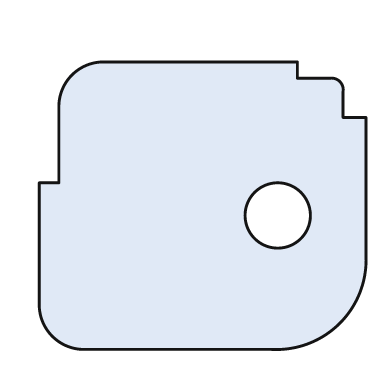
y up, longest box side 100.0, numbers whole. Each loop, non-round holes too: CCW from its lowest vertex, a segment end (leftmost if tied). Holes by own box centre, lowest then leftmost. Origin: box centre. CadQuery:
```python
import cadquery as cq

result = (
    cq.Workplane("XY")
    .moveTo(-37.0, -44.0)
    .lineTo(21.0, -44.0)
    .threePointArc((42.0, -36.0), (50.0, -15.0))
    .lineTo(50.0, 27.0)
    .lineTo(43.0, 27.0)
    .lineTo(43.0, 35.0)
    .threePointArc((42.0, 38.0), (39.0, 39.0))
    .lineTo(29.0, 39.0)
    .lineTo(29.0, 44.0)
    .lineTo(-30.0, 44.0)
    .threePointArc((-40.0, 40.0), (-44.0, 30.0))
    .lineTo(-44.0, 7.0)
    .lineTo(-50.0, 7.0)
    .lineTo(-50.0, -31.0)
    .threePointArc((-46.0, -40.0), (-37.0, -44.0))
    .close()
    .moveTo(23.0, -3.0)
    .circle(10.0)
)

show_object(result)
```